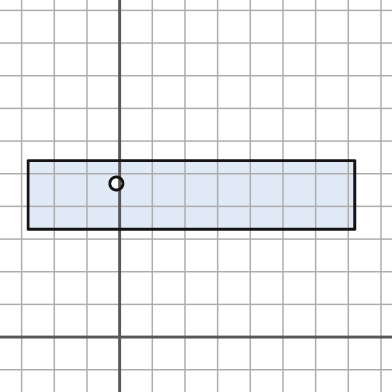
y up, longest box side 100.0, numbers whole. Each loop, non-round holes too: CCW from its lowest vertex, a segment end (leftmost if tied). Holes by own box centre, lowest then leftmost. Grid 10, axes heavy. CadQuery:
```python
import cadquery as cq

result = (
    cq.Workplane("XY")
    .moveTo(-28.0, 33.0)
    .lineTo(72.0, 33.0)
    .lineTo(72.0, 54.0)
    .lineTo(-28.0, 54.0)
    .close()
    .moveTo(-1.0, 47.0)
    .circle(2.0)
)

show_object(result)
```